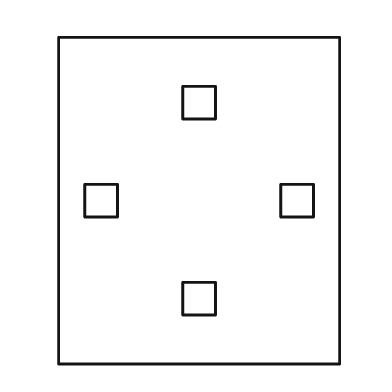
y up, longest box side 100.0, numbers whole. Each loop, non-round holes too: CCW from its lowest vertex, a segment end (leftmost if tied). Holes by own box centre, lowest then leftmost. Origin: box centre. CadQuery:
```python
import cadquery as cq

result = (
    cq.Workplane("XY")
    .moveTo(-43.0, -50.0)
    .lineTo(43.0, -50.0)
    .lineTo(43.0, 50.0)
    .lineTo(-43.0, 50.0)
    .close()
    .moveTo(-5.0, -35.0)
    .lineTo(5.0, -35.0)
    .lineTo(5.0, -25.0)
    .lineTo(-5.0, -25.0)
    .close()
    .moveTo(-35.0, -5.0)
    .lineTo(-25.0, -5.0)
    .lineTo(-25.0, 5.0)
    .lineTo(-35.0, 5.0)
    .close()
    .moveTo(25.0, -5.0)
    .lineTo(35.0, -5.0)
    .lineTo(35.0, 5.0)
    .lineTo(25.0, 5.0)
    .close()
    .moveTo(-5.0, 25.0)
    .lineTo(5.0, 25.0)
    .lineTo(5.0, 35.0)
    .lineTo(-5.0, 35.0)
    .close()
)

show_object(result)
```